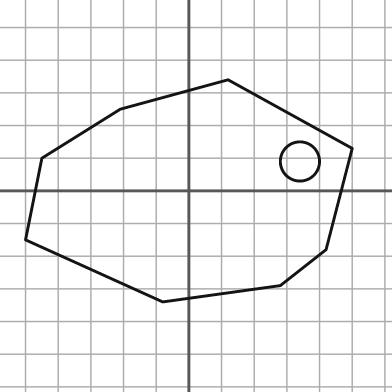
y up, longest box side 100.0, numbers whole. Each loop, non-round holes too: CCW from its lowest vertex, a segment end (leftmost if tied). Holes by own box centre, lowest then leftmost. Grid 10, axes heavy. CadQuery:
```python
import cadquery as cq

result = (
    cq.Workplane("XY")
    .moveTo(-8.0, -34.0)
    .lineTo(28.0, -29.0)
    .lineTo(42.0, -18.0)
    .lineTo(50.0, 13.0)
    .lineTo(12.0, 34.0)
    .lineTo(-21.0, 25.0)
    .lineTo(-45.0, 10.0)
    .lineTo(-50.0, -15.0)
    .close()
    .moveTo(34.0, 9.0)
    .circle(6.0)
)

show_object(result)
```